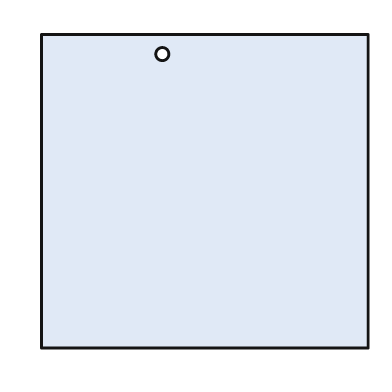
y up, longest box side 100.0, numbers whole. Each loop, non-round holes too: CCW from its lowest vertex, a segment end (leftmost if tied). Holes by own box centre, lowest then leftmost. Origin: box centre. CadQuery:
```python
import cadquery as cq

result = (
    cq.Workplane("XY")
    .moveTo(-50.0, -48.0)
    .lineTo(50.0, -48.0)
    .lineTo(50.0, 48.0)
    .lineTo(-50.0, 48.0)
    .close()
    .moveTo(-13.0, 42.0)
    .circle(2.0)
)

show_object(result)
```